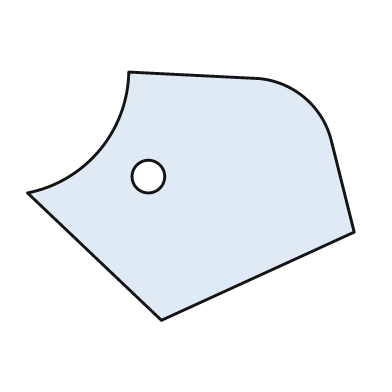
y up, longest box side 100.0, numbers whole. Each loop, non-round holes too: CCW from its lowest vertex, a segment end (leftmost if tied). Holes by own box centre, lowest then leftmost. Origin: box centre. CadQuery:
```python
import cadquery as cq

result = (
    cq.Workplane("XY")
    .moveTo(-9.0, -38.0)
    .lineTo(50.0, -11.0)
    .lineTo(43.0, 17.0)
    .threePointArc((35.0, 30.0), (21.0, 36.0))
    .lineTo(-19.0, 38.0)
    .threePointArc((-28.0, 14.0), (-50.0, 1.0))
    .close()
    .moveTo(-13.0, 6.0)
    .circle(5.0)
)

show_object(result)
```